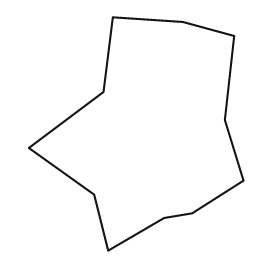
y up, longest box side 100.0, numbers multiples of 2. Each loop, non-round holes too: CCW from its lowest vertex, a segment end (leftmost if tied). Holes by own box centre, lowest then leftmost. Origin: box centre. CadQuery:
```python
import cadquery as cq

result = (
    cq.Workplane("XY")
    .moveTo(-12.0, -50.0)
    .lineTo(12.0, -36.0)
    .lineTo(24.0, -34.0)
    .lineTo(46.0, -20.0)
    .lineTo(38.0, 6.0)
    .lineTo(42.0, 42.0)
    .lineTo(20.0, 48.0)
    .lineTo(-10.0, 50.0)
    .lineTo(-14.0, 18.0)
    .lineTo(-46.0, -6.0)
    .lineTo(-18.0, -26.0)
    .close()
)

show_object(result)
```